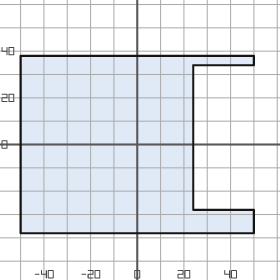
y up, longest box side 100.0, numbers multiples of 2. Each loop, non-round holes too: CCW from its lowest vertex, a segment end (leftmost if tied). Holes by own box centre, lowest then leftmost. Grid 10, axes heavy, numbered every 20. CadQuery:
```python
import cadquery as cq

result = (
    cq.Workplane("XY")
    .moveTo(-50.0, -38.0)
    .lineTo(50.0, -38.0)
    .lineTo(50.0, -28.0)
    .lineTo(24.0, -28.0)
    .lineTo(24.0, 34.0)
    .lineTo(50.0, 34.0)
    .lineTo(50.0, 38.0)
    .lineTo(-50.0, 38.0)
    .close()
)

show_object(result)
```